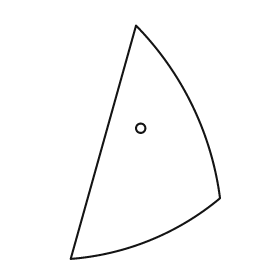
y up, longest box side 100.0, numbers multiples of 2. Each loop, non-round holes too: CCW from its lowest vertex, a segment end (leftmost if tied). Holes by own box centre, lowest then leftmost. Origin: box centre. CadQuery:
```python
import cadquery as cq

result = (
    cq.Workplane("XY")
    .moveTo(-32.0, -50.0)
    .threePointArc((2.0, -42.0), (32.0, -24.0))
    .threePointArc((20.0, 16.0), (-4.0, 50.0))
    .close()
    .moveTo(-2.0, 6.0)
    .circle(2.0)
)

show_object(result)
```